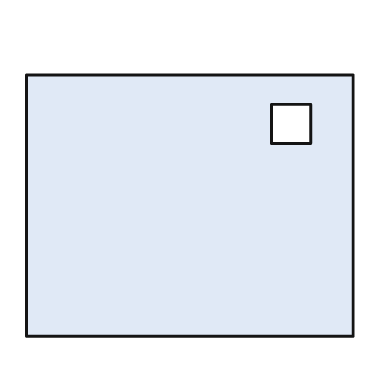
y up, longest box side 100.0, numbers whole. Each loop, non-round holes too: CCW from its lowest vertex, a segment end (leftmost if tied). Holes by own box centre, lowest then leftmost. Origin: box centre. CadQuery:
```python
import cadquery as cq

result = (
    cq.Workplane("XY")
    .moveTo(-50.0, -40.0)
    .lineTo(50.0, -40.0)
    .lineTo(50.0, 40.0)
    .lineTo(-50.0, 40.0)
    .close()
    .moveTo(25.0, 19.0)
    .lineTo(37.0, 19.0)
    .lineTo(37.0, 31.0)
    .lineTo(25.0, 31.0)
    .close()
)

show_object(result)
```